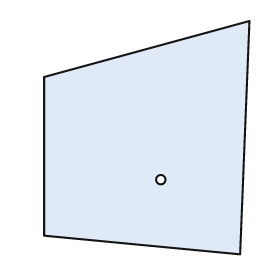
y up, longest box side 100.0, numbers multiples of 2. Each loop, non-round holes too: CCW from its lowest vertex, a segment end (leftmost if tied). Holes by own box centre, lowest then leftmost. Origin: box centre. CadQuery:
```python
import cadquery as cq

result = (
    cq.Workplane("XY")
    .moveTo(40.0, -50.0)
    .lineTo(44.0, 50.0)
    .lineTo(-44.0, 26.0)
    .lineTo(-44.0, -42.0)
    .close()
    .moveTo(6.0, -18.0)
    .circle(2.0)
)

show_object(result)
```